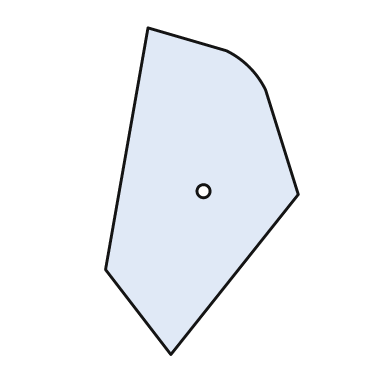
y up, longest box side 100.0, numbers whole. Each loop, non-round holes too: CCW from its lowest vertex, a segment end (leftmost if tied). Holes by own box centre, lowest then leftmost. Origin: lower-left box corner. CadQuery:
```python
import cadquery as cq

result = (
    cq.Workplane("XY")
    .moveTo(20.0, 0.0)
    .lineTo(59.0, 49.0)
    .lineTo(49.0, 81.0)
    .threePointArc((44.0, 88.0), (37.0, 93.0))
    .lineTo(13.0, 100.0)
    .lineTo(0.0, 26.0)
    .close()
    .moveTo(30.0, 50.0)
    .circle(2.0)
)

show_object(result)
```